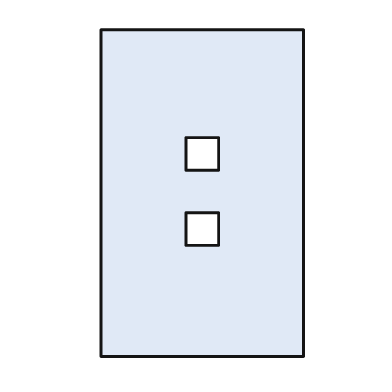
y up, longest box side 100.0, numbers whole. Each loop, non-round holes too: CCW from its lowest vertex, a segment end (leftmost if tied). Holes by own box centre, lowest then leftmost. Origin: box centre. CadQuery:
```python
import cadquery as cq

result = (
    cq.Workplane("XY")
    .moveTo(-31.0, -50.0)
    .lineTo(31.0, -50.0)
    .lineTo(31.0, 50.0)
    .lineTo(-31.0, 50.0)
    .close()
    .moveTo(-5.0, -16.0)
    .lineTo(5.0, -16.0)
    .lineTo(5.0, -6.0)
    .lineTo(-5.0, -6.0)
    .close()
    .moveTo(-5.0, 7.0)
    .lineTo(5.0, 7.0)
    .lineTo(5.0, 17.0)
    .lineTo(-5.0, 17.0)
    .close()
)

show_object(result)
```